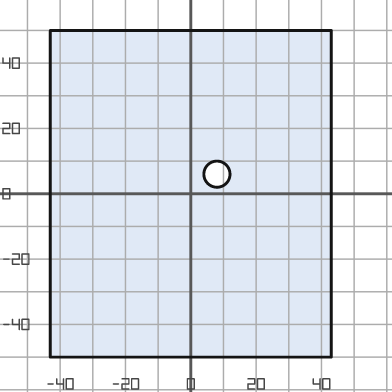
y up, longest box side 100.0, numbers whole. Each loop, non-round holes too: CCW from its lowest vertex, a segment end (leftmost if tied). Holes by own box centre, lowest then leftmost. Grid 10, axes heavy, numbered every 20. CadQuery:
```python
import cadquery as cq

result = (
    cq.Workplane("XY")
    .moveTo(-43.0, -50.0)
    .lineTo(43.0, -50.0)
    .lineTo(43.0, 50.0)
    .lineTo(-43.0, 50.0)
    .close()
    .moveTo(8.0, 6.0)
    .circle(4.0)
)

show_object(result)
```